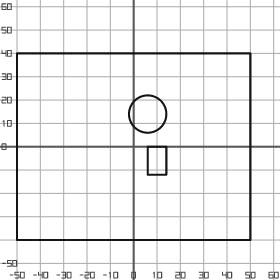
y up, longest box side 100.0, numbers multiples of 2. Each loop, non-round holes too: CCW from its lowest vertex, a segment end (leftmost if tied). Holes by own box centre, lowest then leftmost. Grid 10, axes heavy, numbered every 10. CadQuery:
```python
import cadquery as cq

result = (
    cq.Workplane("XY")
    .moveTo(-50.0, -40.0)
    .lineTo(50.0, -40.0)
    .lineTo(50.0, 40.0)
    .lineTo(-50.0, 40.0)
    .close()
    .moveTo(6.0, -12.0)
    .lineTo(14.0, -12.0)
    .lineTo(14.0, 0.0)
    .lineTo(6.0, 0.0)
    .close()
    .moveTo(6.0, 14.0)
    .circle(8.0)
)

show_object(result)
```